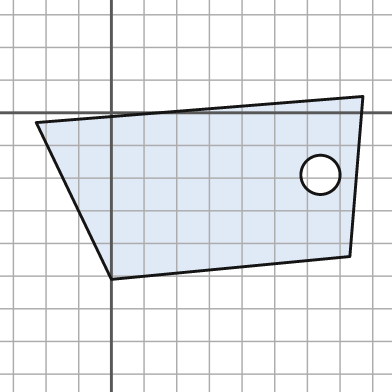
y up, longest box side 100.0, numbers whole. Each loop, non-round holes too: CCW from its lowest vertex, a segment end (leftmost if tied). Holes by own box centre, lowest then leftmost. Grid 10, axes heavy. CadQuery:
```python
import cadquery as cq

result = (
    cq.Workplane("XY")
    .moveTo(0.0, -51.0)
    .lineTo(73.0, -44.0)
    .lineTo(77.0, 5.0)
    .lineTo(-23.0, -3.0)
    .close()
    .moveTo(64.0, -19.0)
    .circle(6.0)
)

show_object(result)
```